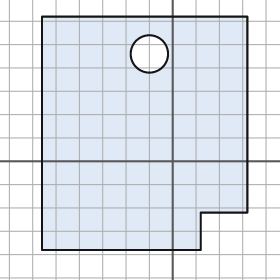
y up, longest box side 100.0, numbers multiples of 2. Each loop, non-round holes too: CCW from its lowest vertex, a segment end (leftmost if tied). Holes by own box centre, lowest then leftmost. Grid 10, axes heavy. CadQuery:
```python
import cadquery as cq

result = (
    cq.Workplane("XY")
    .moveTo(-56.0, -38.0)
    .lineTo(12.0, -38.0)
    .lineTo(12.0, -22.0)
    .lineTo(32.0, -22.0)
    .lineTo(32.0, 62.0)
    .lineTo(-56.0, 62.0)
    .close()
    .moveTo(-10.0, 46.0)
    .circle(8.0)
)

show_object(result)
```